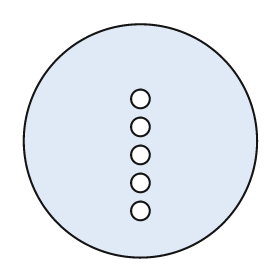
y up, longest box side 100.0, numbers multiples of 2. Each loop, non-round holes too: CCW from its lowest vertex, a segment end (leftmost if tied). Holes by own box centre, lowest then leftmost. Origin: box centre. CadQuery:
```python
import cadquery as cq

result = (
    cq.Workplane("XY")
    .moveTo(0.0, 0.0)
    .circle(50.0)
    .moveTo(0.0, -30.0)
    .circle(4.0)
    .moveTo(0.0, -18.0)
    .circle(4.0)
    .moveTo(0.0, -6.0)
    .circle(4.0)
    .moveTo(0.0, 6.0)
    .circle(4.0)
    .moveTo(0.0, 18.0)
    .circle(4.0)
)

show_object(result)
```